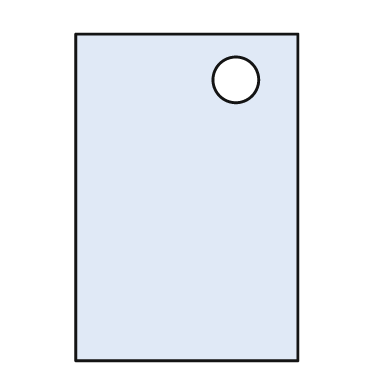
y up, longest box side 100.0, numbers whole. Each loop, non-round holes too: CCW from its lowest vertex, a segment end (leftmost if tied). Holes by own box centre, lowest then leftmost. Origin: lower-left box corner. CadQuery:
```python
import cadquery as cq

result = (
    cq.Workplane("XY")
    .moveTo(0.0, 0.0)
    .lineTo(68.0, 0.0)
    .lineTo(68.0, 100.0)
    .lineTo(0.0, 100.0)
    .close()
    .moveTo(49.0, 86.0)
    .circle(7.0)
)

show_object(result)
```